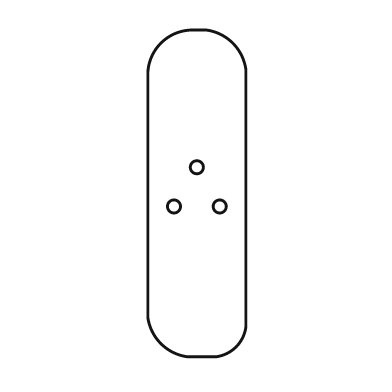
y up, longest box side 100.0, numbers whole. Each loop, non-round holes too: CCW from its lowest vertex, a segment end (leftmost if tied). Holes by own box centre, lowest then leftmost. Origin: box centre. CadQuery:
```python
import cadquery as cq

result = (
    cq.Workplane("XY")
    .moveTo(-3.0, -50.0)
    .lineTo(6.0, -50.0)
    .threePointArc((12.0, -47.0), (15.0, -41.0))
    .lineTo(15.0, 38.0)
    .threePointArc((11.0, 46.0), (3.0, 50.0))
    .lineTo(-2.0, 50.0)
    .threePointArc((-11.0, 46.0), (-15.0, 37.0))
    .lineTo(-15.0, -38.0)
    .threePointArc((-11.0, -46.0), (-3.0, -50.0))
    .close()
    .moveTo(-7.0, -4.0)
    .circle(2.0)
    .moveTo(7.0, -4.0)
    .circle(2.0)
    .moveTo(0.0, 8.0)
    .circle(2.0)
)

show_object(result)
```